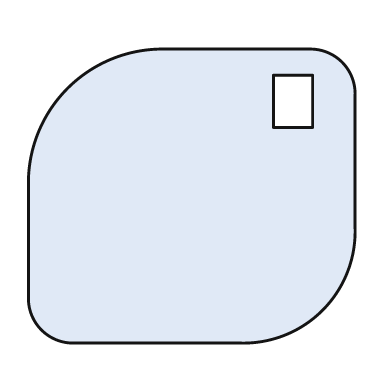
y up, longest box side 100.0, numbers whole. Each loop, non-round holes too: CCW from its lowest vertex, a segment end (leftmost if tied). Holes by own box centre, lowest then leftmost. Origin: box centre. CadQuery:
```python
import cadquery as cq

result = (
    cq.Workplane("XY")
    .moveTo(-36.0, -45.0)
    .lineTo(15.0, -45.0)
    .threePointArc((40.0, -35.0), (50.0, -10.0))
    .lineTo(50.0, 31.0)
    .threePointArc((46.0, 41.0), (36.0, 45.0))
    .lineTo(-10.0, 45.0)
    .threePointArc((-38.0, 33.0), (-50.0, 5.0))
    .lineTo(-50.0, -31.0)
    .threePointArc((-46.0, -41.0), (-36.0, -45.0))
    .close()
    .moveTo(25.0, 21.0)
    .lineTo(37.0, 21.0)
    .lineTo(37.0, 37.0)
    .lineTo(25.0, 37.0)
    .close()
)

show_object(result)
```